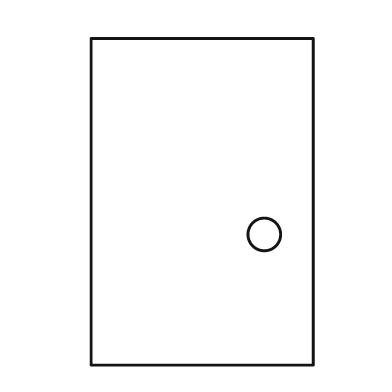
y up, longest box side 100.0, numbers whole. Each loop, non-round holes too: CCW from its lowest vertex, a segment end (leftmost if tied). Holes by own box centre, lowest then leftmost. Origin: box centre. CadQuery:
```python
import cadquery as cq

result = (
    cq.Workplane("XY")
    .moveTo(-34.0, -50.0)
    .lineTo(34.0, -50.0)
    .lineTo(34.0, 50.0)
    .lineTo(-34.0, 50.0)
    .close()
    .moveTo(19.0, -10.0)
    .circle(5.0)
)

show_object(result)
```